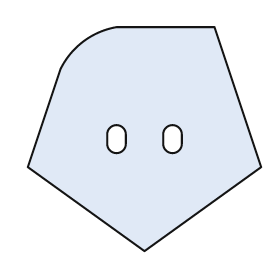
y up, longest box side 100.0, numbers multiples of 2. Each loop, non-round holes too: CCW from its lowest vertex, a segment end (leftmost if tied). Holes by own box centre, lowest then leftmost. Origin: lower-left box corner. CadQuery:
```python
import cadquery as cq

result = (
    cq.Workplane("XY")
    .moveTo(50.0, 0.0)
    .lineTo(100.0, 36.0)
    .lineTo(80.0, 96.0)
    .lineTo(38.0, 96.0)
    .threePointArc((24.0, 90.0), (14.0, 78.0))
    .lineTo(0.0, 36.0)
    .close()
    .moveTo(34.0, 46.0)
    .threePointArc((38.0, 42.0), (42.0, 46.0))
    .lineTo(42.0, 50.0)
    .threePointArc((38.0, 54.0), (34.0, 50.0))
    .close()
    .moveTo(58.0, 46.0)
    .threePointArc((62.0, 42.0), (66.0, 46.0))
    .lineTo(66.0, 50.0)
    .threePointArc((62.0, 54.0), (58.0, 50.0))
    .close()
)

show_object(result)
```